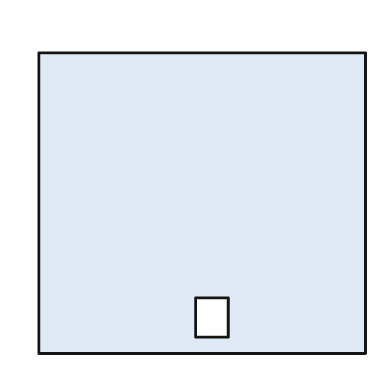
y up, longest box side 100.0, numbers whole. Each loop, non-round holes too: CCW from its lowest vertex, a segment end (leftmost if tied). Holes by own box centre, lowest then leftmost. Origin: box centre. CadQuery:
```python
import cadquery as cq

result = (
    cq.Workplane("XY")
    .moveTo(-50.0, -46.0)
    .lineTo(50.0, -46.0)
    .lineTo(50.0, 46.0)
    .lineTo(-50.0, 46.0)
    .close()
    .moveTo(-2.0, -41.0)
    .lineTo(8.0, -41.0)
    .lineTo(8.0, -29.0)
    .lineTo(-2.0, -29.0)
    .close()
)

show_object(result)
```